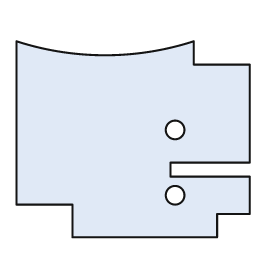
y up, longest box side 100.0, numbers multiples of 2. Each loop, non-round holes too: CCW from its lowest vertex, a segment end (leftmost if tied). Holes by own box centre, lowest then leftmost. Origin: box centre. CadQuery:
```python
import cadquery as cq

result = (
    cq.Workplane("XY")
    .moveTo(-26.0, -42.0)
    .lineTo(36.0, -42.0)
    .lineTo(36.0, -32.0)
    .lineTo(50.0, -32.0)
    .lineTo(50.0, -16.0)
    .lineTo(16.0, -16.0)
    .lineTo(16.0, -10.0)
    .lineTo(50.0, -10.0)
    .lineTo(50.0, 32.0)
    .lineTo(26.0, 32.0)
    .lineTo(26.0, 42.0)
    .threePointArc((-12.0, 36.0), (-50.0, 42.0))
    .lineTo(-50.0, -28.0)
    .lineTo(-26.0, -28.0)
    .close()
    .moveTo(18.0, -24.0)
    .circle(4.0)
    .moveTo(18.0, 4.0)
    .circle(4.0)
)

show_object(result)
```